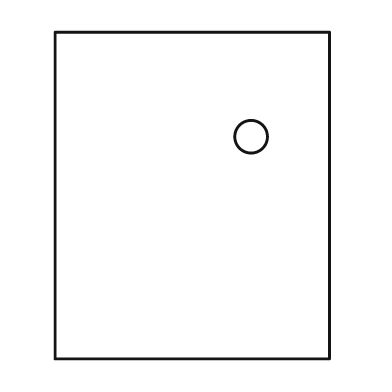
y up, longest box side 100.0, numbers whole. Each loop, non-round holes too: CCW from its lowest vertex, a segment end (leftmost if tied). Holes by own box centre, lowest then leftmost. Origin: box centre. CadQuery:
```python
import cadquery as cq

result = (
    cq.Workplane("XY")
    .moveTo(-42.0, -50.0)
    .lineTo(42.0, -50.0)
    .lineTo(42.0, 50.0)
    .lineTo(-42.0, 50.0)
    .close()
    .moveTo(18.0, 18.0)
    .circle(5.0)
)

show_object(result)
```